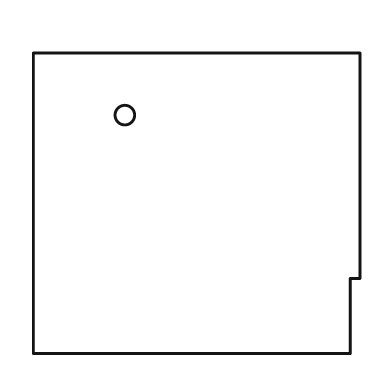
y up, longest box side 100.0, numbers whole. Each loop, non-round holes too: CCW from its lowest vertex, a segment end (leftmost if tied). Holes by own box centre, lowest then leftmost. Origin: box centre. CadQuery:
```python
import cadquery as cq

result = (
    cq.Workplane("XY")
    .moveTo(-50.0, -46.0)
    .lineTo(47.0, -46.0)
    .lineTo(47.0, -23.0)
    .lineTo(50.0, -23.0)
    .lineTo(50.0, 46.0)
    .lineTo(-50.0, 46.0)
    .close()
    .moveTo(-22.0, 27.0)
    .circle(3.0)
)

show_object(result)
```